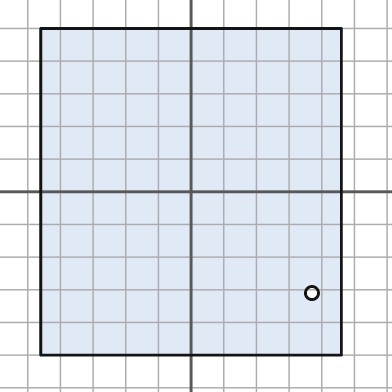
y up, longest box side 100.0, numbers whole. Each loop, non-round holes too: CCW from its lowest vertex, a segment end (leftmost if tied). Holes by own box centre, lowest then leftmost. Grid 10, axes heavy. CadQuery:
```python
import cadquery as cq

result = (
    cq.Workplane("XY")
    .moveTo(-46.0, -50.0)
    .lineTo(46.0, -50.0)
    .lineTo(46.0, 50.0)
    .lineTo(-46.0, 50.0)
    .close()
    .moveTo(37.0, -31.0)
    .circle(2.0)
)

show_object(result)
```